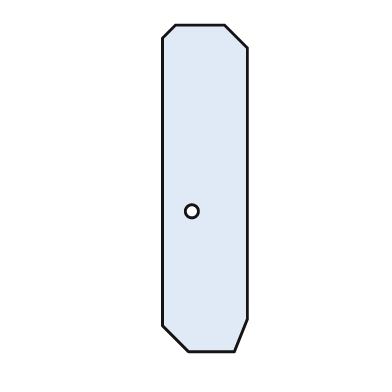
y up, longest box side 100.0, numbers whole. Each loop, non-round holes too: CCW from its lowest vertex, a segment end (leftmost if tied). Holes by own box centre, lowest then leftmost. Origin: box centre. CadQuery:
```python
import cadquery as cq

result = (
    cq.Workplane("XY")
    .moveTo(-5.0, -50.0)
    .lineTo(9.0, -50.0)
    .lineTo(13.0, -40.0)
    .lineTo(13.0, 43.0)
    .lineTo(6.0, 50.0)
    .lineTo(-9.0, 50.0)
    .lineTo(-13.0, 46.0)
    .lineTo(-13.0, -42.0)
    .close()
    .moveTo(-4.0, -7.0)
    .circle(2.0)
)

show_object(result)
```